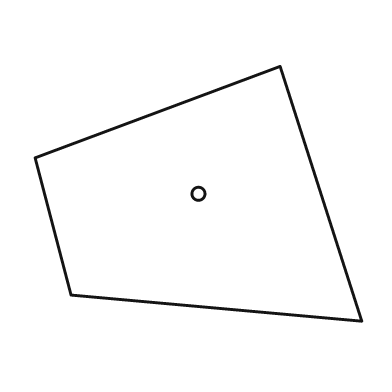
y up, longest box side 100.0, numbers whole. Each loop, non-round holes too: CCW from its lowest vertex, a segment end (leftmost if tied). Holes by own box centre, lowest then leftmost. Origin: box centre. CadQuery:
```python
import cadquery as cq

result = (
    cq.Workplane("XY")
    .moveTo(50.0, -39.0)
    .lineTo(25.0, 39.0)
    .lineTo(-50.0, 11.0)
    .lineTo(-39.0, -31.0)
    .close()
    .moveTo(0.0, 0.0)
    .circle(2.0)
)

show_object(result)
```